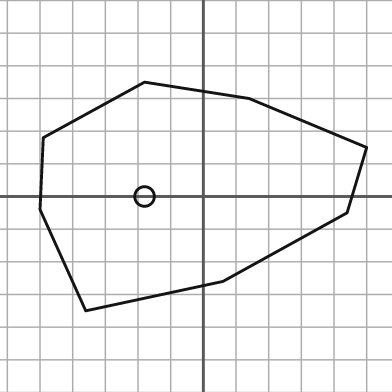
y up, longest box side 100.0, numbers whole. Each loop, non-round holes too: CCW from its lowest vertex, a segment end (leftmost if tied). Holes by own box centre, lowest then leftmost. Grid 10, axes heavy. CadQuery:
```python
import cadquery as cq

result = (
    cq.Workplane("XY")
    .moveTo(-36.0, -35.0)
    .lineTo(6.0, -26.0)
    .lineTo(44.0, -5.0)
    .lineTo(50.0, 15.0)
    .lineTo(14.0, 30.0)
    .lineTo(-18.0, 35.0)
    .lineTo(-49.0, 18.0)
    .lineTo(-50.0, -4.0)
    .close()
    .moveTo(-18.0, 0.0)
    .circle(3.0)
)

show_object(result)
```